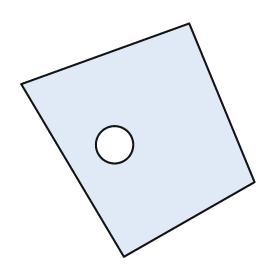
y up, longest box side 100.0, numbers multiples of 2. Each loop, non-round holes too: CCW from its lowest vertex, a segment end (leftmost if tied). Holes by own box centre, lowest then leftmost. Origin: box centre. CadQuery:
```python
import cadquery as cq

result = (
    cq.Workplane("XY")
    .moveTo(-6.0, -50.0)
    .lineTo(50.0, -18.0)
    .lineTo(22.0, 50.0)
    .lineTo(-50.0, 24.0)
    .close()
    .moveTo(-10.0, -2.0)
    .circle(8.0)
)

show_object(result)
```